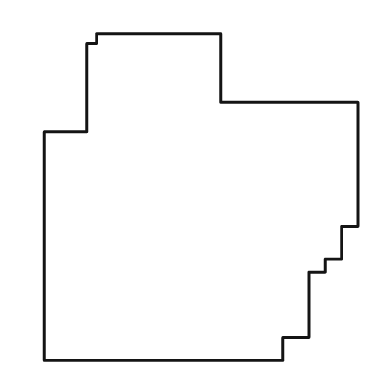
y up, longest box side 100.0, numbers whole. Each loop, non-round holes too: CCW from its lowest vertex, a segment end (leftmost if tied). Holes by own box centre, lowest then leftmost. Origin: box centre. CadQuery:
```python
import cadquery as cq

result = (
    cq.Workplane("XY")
    .moveTo(-48.0, -50.0)
    .lineTo(25.0, -50.0)
    .lineTo(25.0, -43.0)
    .lineTo(33.0, -43.0)
    .lineTo(33.0, -23.0)
    .lineTo(38.0, -23.0)
    .lineTo(38.0, -19.0)
    .lineTo(43.0, -19.0)
    .lineTo(43.0, -9.0)
    .lineTo(48.0, -9.0)
    .lineTo(48.0, 29.0)
    .lineTo(6.0, 29.0)
    .lineTo(6.0, 50.0)
    .lineTo(-32.0, 50.0)
    .lineTo(-32.0, 47.0)
    .lineTo(-35.0, 47.0)
    .lineTo(-35.0, 20.0)
    .lineTo(-48.0, 20.0)
    .close()
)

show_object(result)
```